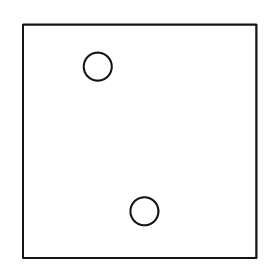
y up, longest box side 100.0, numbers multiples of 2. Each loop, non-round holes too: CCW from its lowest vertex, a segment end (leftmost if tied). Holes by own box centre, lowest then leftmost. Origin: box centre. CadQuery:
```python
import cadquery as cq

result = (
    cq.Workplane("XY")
    .moveTo(-50.0, -50.0)
    .lineTo(50.0, -50.0)
    .lineTo(50.0, 50.0)
    .lineTo(-50.0, 50.0)
    .close()
    .moveTo(2.0, -30.0)
    .circle(6.0)
    .moveTo(-18.0, 32.0)
    .circle(6.0)
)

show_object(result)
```